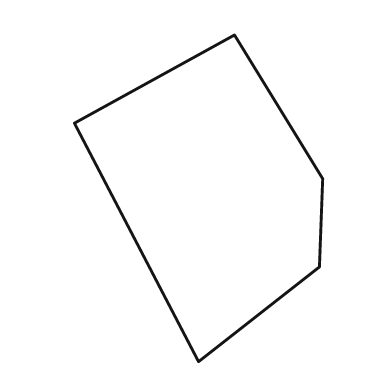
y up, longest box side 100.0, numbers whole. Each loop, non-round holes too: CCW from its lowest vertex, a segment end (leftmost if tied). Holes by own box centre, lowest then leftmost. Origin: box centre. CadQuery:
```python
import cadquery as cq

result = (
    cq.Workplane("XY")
    .moveTo(0.0, -50.0)
    .lineTo(37.0, -21.0)
    .lineTo(38.0, 6.0)
    .lineTo(11.0, 50.0)
    .lineTo(-38.0, 23.0)
    .close()
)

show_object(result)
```